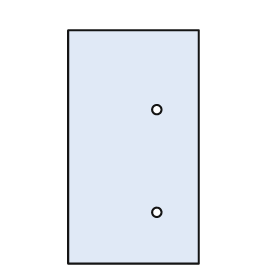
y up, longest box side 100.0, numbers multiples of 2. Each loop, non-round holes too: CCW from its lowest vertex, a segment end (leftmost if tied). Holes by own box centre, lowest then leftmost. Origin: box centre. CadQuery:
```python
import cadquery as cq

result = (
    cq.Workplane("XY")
    .moveTo(-28.0, -50.0)
    .lineTo(28.0, -50.0)
    .lineTo(28.0, 50.0)
    .lineTo(-28.0, 50.0)
    .close()
    .moveTo(10.0, -28.0)
    .circle(2.0)
    .moveTo(10.0, 16.0)
    .circle(2.0)
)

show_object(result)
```